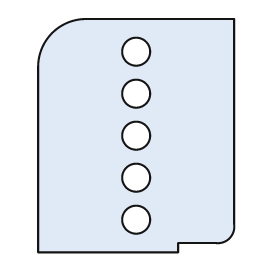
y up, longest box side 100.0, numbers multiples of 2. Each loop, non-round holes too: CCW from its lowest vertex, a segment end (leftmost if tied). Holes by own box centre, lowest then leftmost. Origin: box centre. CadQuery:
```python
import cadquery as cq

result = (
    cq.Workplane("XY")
    .moveTo(-42.0, -50.0)
    .lineTo(18.0, -50.0)
    .lineTo(18.0, -46.0)
    .lineTo(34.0, -46.0)
    .threePointArc((40.0, -44.0), (42.0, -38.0))
    .lineTo(42.0, 50.0)
    .lineTo(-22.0, 50.0)
    .threePointArc((-36.0, 44.0), (-42.0, 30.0))
    .close()
    .moveTo(0.0, -36.0)
    .circle(6.0)
    .moveTo(0.0, -18.0)
    .circle(6.0)
    .moveTo(0.0, 0.0)
    .circle(6.0)
    .moveTo(0.0, 18.0)
    .circle(6.0)
    .moveTo(0.0, 36.0)
    .circle(6.0)
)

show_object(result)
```